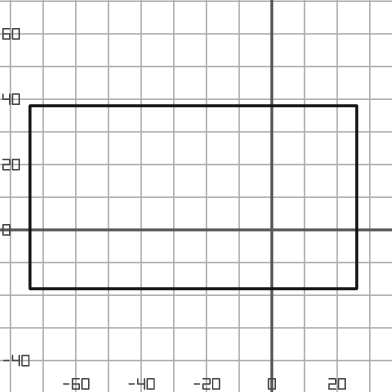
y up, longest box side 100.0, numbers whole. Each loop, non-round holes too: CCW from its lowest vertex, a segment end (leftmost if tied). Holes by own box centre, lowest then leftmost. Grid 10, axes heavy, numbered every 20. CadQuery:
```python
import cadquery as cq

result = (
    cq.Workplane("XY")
    .moveTo(-74.0, -18.0)
    .lineTo(26.0, -18.0)
    .lineTo(26.0, 38.0)
    .lineTo(-74.0, 38.0)
    .close()
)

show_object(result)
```